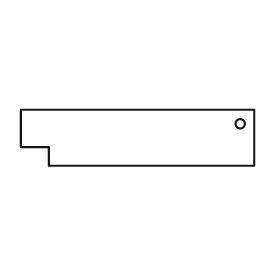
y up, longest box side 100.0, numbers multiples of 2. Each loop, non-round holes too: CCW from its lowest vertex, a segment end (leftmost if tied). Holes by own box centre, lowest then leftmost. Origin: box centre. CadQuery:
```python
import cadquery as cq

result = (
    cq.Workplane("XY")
    .moveTo(-38.0, -12.0)
    .lineTo(50.0, -12.0)
    .lineTo(50.0, 12.0)
    .lineTo(-50.0, 12.0)
    .lineTo(-50.0, -4.0)
    .lineTo(-38.0, -4.0)
    .close()
    .moveTo(44.0, 6.0)
    .circle(2.0)
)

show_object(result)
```